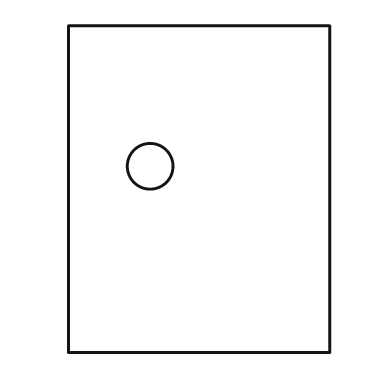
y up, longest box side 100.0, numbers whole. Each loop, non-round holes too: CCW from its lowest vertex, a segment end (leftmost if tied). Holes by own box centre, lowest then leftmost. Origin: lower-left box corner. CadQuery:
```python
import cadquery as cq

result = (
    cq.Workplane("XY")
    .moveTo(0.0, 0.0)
    .lineTo(80.0, 0.0)
    .lineTo(80.0, 100.0)
    .lineTo(0.0, 100.0)
    .close()
    .moveTo(25.0, 57.0)
    .circle(7.0)
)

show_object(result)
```